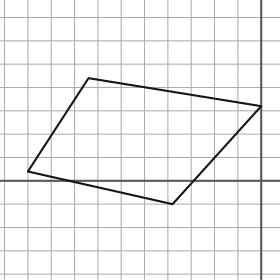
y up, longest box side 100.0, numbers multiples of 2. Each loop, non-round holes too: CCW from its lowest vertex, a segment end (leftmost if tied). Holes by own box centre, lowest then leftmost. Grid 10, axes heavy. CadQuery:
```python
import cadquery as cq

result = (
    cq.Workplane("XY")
    .moveTo(-38.0, -10.0)
    .lineTo(0.0, 32.0)
    .lineTo(-74.0, 44.0)
    .lineTo(-100.0, 4.0)
    .close()
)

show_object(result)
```